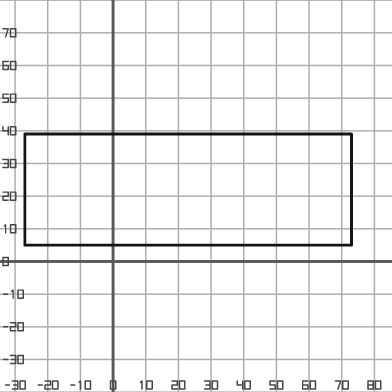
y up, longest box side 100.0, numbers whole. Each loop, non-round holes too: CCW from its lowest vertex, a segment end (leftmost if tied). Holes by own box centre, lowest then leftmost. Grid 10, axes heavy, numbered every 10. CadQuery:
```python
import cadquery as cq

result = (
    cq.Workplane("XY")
    .moveTo(-27.0, 5.0)
    .lineTo(73.0, 5.0)
    .lineTo(73.0, 39.0)
    .lineTo(-27.0, 39.0)
    .close()
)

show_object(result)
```